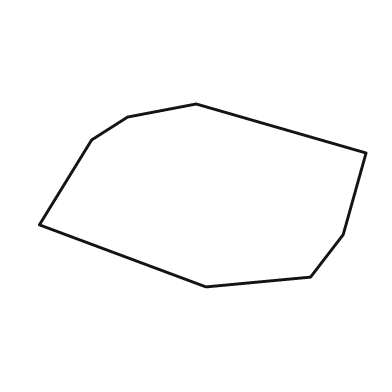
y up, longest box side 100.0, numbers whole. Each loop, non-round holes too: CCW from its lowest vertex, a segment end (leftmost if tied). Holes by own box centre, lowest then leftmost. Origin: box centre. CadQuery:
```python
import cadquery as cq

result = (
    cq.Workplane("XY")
    .moveTo(1.0, -28.0)
    .lineTo(33.0, -25.0)
    .lineTo(43.0, -12.0)
    .lineTo(50.0, 13.0)
    .lineTo(-2.0, 28.0)
    .lineTo(-23.0, 24.0)
    .lineTo(-34.0, 17.0)
    .lineTo(-50.0, -9.0)
    .close()
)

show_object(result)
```